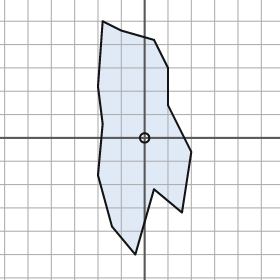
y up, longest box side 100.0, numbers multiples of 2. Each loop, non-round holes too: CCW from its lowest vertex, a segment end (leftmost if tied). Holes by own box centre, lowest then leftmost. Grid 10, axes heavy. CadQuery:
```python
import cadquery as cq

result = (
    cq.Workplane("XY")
    .moveTo(-4.0, -50.0)
    .lineTo(4.0, -22.0)
    .lineTo(16.0, -32.0)
    .lineTo(20.0, -6.0)
    .lineTo(10.0, 14.0)
    .lineTo(10.0, 30.0)
    .lineTo(4.0, 42.0)
    .lineTo(-10.0, 46.0)
    .lineTo(-18.0, 50.0)
    .lineTo(-20.0, 22.0)
    .lineTo(-18.0, 6.0)
    .lineTo(-20.0, -16.0)
    .lineTo(-14.0, -38.0)
    .close()
    .moveTo(0.0, 0.0)
    .circle(2.0)
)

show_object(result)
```